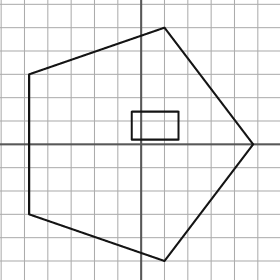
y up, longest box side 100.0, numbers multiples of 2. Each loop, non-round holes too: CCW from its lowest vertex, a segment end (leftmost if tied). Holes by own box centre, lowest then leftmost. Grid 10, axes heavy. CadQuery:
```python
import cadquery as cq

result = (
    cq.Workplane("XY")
    .moveTo(10.0, -50.0)
    .lineTo(48.0, 0.0)
    .lineTo(10.0, 50.0)
    .lineTo(-48.0, 30.0)
    .lineTo(-48.0, -30.0)
    .close()
    .moveTo(-4.0, 2.0)
    .lineTo(16.0, 2.0)
    .lineTo(16.0, 14.0)
    .lineTo(-4.0, 14.0)
    .close()
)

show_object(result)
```